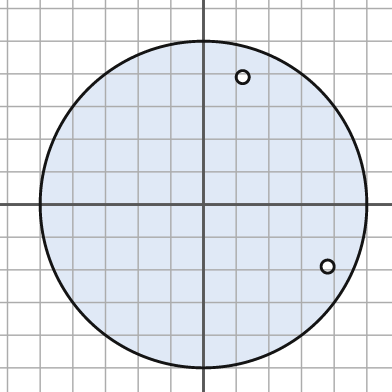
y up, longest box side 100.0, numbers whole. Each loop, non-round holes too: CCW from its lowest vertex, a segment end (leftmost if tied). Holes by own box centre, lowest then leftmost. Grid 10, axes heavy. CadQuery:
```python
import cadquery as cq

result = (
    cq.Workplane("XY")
    .moveTo(0.0, 0.0)
    .circle(50.0)
    .moveTo(38.0, -19.0)
    .circle(2.0)
    .moveTo(12.0, 39.0)
    .circle(2.0)
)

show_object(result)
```